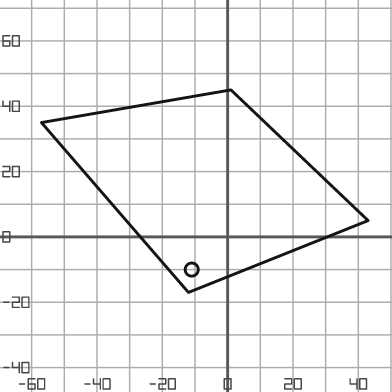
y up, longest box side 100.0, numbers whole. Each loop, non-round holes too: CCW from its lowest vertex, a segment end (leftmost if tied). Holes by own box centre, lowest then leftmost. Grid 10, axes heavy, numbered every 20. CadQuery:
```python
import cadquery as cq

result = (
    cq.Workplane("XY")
    .moveTo(-12.0, -17.0)
    .lineTo(43.0, 5.0)
    .lineTo(1.0, 45.0)
    .lineTo(-57.0, 35.0)
    .close()
    .moveTo(-11.0, -10.0)
    .circle(2.0)
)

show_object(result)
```